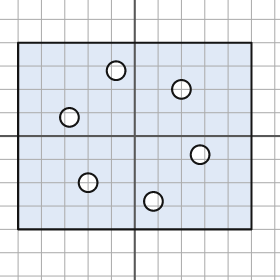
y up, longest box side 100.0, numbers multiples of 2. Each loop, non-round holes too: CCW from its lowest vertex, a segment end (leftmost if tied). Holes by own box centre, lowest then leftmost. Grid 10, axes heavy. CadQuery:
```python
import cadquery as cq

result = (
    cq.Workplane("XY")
    .moveTo(-50.0, -40.0)
    .lineTo(50.0, -40.0)
    .lineTo(50.0, 40.0)
    .lineTo(-50.0, 40.0)
    .close()
    .moveTo(8.0, -28.0)
    .circle(4.0)
    .moveTo(-20.0, -20.0)
    .circle(4.0)
    .moveTo(28.0, -8.0)
    .circle(4.0)
    .moveTo(-28.0, 8.0)
    .circle(4.0)
    .moveTo(20.0, 20.0)
    .circle(4.0)
    .moveTo(-8.0, 28.0)
    .circle(4.0)
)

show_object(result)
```